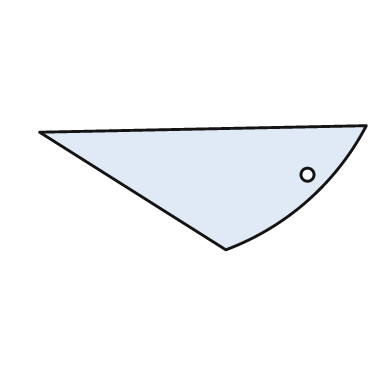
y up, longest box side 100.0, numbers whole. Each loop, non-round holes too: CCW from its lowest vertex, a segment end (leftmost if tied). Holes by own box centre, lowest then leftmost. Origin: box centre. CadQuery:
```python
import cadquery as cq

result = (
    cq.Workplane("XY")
    .moveTo(7.0, -19.0)
    .threePointArc((32.0, -4.0), (50.0, 19.0))
    .lineTo(-50.0, 17.0)
    .close()
    .moveTo(32.0, 4.0)
    .circle(2.0)
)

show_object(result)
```